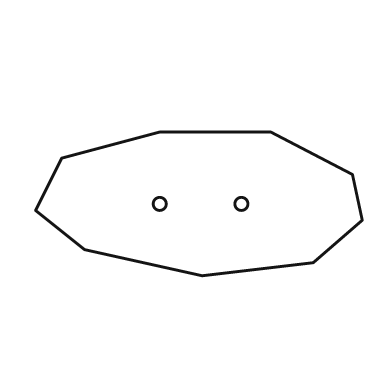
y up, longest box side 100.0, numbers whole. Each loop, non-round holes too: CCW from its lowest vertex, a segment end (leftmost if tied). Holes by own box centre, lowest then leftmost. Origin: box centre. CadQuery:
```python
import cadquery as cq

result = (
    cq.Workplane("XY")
    .moveTo(1.0, -22.0)
    .lineTo(35.0, -18.0)
    .lineTo(50.0, -5.0)
    .lineTo(47.0, 9.0)
    .lineTo(22.0, 22.0)
    .lineTo(-12.0, 22.0)
    .lineTo(-42.0, 14.0)
    .lineTo(-50.0, -2.0)
    .lineTo(-35.0, -14.0)
    .close()
    .moveTo(-12.0, 0.0)
    .circle(2.0)
    .moveTo(13.0, 0.0)
    .circle(2.0)
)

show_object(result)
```